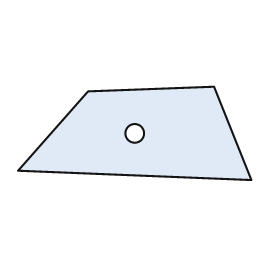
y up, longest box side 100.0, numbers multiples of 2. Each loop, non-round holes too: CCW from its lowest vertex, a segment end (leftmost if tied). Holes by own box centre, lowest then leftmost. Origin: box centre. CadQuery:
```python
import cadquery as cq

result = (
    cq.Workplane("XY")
    .moveTo(50.0, -20.0)
    .lineTo(34.0, 20.0)
    .lineTo(-20.0, 18.0)
    .lineTo(-50.0, -16.0)
    .close()
    .moveTo(0.0, 0.0)
    .circle(4.0)
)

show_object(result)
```